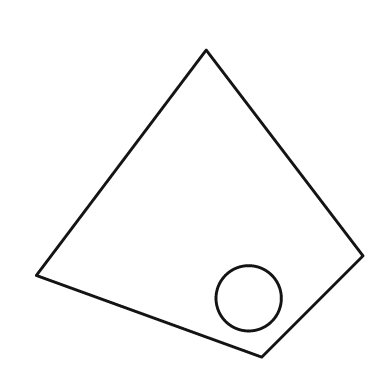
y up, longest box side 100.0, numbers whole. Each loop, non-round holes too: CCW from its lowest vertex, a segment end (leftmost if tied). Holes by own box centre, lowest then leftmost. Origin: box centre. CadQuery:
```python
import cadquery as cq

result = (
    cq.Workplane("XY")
    .moveTo(19.0, -47.0)
    .lineTo(50.0, -16.0)
    .lineTo(2.0, 47.0)
    .lineTo(-50.0, -22.0)
    .close()
    .moveTo(15.0, -29.0)
    .circle(10.0)
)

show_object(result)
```